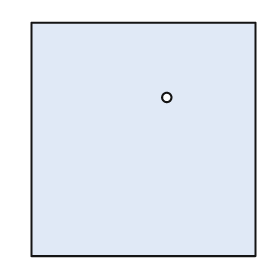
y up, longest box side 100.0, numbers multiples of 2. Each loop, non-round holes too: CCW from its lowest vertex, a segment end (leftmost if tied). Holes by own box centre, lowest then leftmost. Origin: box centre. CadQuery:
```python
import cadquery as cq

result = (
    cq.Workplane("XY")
    .moveTo(-48.0, -50.0)
    .lineTo(48.0, -50.0)
    .lineTo(48.0, 50.0)
    .lineTo(-48.0, 50.0)
    .close()
    .moveTo(10.0, 18.0)
    .circle(2.0)
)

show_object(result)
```